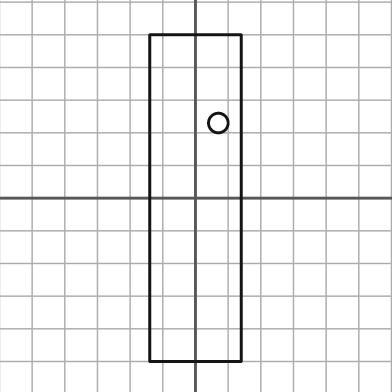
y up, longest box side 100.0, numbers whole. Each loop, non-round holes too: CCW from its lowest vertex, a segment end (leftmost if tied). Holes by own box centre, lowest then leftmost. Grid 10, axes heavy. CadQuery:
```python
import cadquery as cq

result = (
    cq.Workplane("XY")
    .moveTo(-14.0, -50.0)
    .lineTo(14.0, -50.0)
    .lineTo(14.0, 50.0)
    .lineTo(-14.0, 50.0)
    .close()
    .moveTo(7.0, 23.0)
    .circle(3.0)
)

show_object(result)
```